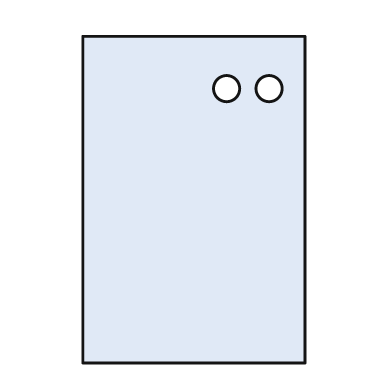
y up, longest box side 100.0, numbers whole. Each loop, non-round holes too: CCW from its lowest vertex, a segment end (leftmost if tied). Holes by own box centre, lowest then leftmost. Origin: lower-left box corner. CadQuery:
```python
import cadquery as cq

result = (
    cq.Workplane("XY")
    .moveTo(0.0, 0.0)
    .lineTo(68.0, 0.0)
    .lineTo(68.0, 100.0)
    .lineTo(0.0, 100.0)
    .close()
    .moveTo(44.0, 84.0)
    .circle(4.0)
    .moveTo(57.0, 84.0)
    .circle(4.0)
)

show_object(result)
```